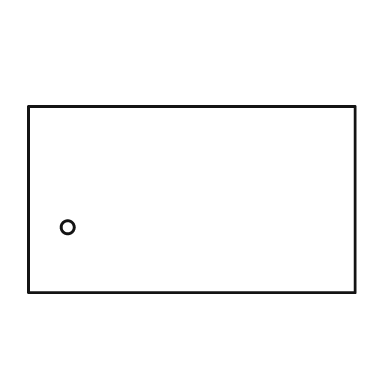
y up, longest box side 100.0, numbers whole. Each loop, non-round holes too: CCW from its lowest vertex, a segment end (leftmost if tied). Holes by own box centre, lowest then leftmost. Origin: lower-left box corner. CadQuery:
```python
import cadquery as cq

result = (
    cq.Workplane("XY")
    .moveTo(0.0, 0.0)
    .lineTo(100.0, 0.0)
    .lineTo(100.0, 57.0)
    .lineTo(0.0, 57.0)
    .close()
    .moveTo(12.0, 20.0)
    .circle(2.0)
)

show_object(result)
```